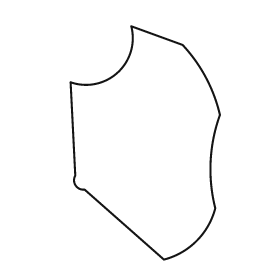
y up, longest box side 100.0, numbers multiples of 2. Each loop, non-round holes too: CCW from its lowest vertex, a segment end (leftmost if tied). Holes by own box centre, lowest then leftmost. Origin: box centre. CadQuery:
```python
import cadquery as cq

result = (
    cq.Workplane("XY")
    .moveTo(8.0, -50.0)
    .threePointArc((22.0, -42.0), (30.0, -28.0))
    .threePointArc((28.0, -8.0), (32.0, 12.0))
    .threePointArc((26.0, 28.0), (16.0, 42.0))
    .lineTo(-6.0, 50.0)
    .threePointArc((-12.0, 30.0), (-32.0, 26.0))
    .lineTo(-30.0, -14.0)
    .threePointArc((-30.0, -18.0), (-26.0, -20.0))
    .close()
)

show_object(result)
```